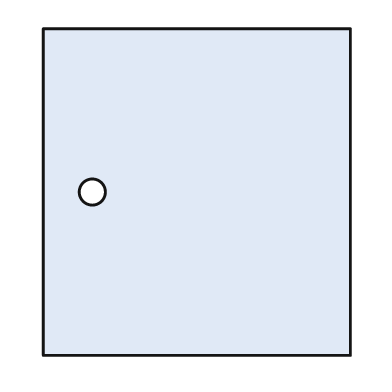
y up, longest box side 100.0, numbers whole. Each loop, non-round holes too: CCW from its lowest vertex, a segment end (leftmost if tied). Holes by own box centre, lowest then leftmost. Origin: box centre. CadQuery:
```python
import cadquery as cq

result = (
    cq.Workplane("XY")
    .moveTo(-47.0, -50.0)
    .lineTo(47.0, -50.0)
    .lineTo(47.0, 50.0)
    .lineTo(-47.0, 50.0)
    .close()
    .moveTo(-32.0, 0.0)
    .circle(4.0)
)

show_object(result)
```